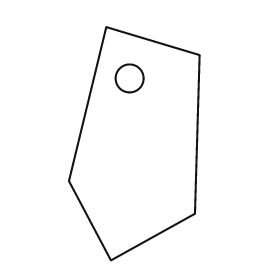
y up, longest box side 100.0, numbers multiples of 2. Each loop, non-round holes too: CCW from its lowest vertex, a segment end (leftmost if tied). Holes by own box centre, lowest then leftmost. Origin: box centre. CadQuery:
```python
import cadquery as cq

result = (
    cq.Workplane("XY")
    .moveTo(-10.0, -50.0)
    .lineTo(26.0, -30.0)
    .lineTo(28.0, 38.0)
    .lineTo(-12.0, 50.0)
    .lineTo(-28.0, -16.0)
    .close()
    .moveTo(-2.0, 28.0)
    .circle(6.0)
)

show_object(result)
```